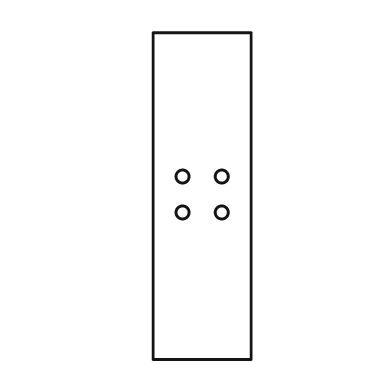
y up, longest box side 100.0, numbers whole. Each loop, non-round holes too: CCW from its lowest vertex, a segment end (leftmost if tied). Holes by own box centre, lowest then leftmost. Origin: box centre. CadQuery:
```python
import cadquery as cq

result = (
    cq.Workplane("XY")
    .moveTo(-15.0, -50.0)
    .lineTo(15.0, -50.0)
    .lineTo(15.0, 50.0)
    .lineTo(-15.0, 50.0)
    .close()
    .moveTo(-6.0, -5.0)
    .circle(2.0)
    .moveTo(6.0, -5.0)
    .circle(2.0)
    .moveTo(-6.0, 6.0)
    .circle(2.0)
    .moveTo(6.0, 6.0)
    .circle(2.0)
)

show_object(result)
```